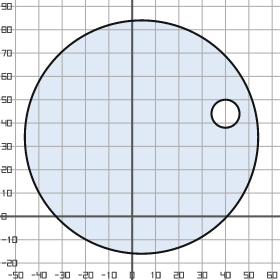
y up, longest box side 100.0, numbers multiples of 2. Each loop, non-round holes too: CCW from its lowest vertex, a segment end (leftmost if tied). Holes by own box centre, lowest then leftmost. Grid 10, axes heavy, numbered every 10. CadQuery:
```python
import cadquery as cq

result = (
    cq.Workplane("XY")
    .moveTo(4.0, 34.0)
    .circle(50.0)
    .moveTo(40.0, 44.0)
    .circle(6.0)
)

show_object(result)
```